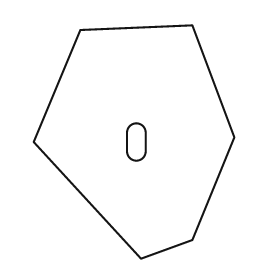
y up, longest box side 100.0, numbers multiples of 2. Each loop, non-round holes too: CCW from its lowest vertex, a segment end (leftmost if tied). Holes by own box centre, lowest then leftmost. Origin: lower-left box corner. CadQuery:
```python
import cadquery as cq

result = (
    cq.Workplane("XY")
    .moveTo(46.0, 0.0)
    .lineTo(68.0, 8.0)
    .lineTo(86.0, 52.0)
    .lineTo(68.0, 100.0)
    .lineTo(20.0, 98.0)
    .lineTo(0.0, 50.0)
    .close()
    .moveTo(40.0, 46.0)
    .threePointArc((44.0, 42.0), (48.0, 46.0))
    .lineTo(48.0, 54.0)
    .threePointArc((44.0, 58.0), (40.0, 54.0))
    .close()
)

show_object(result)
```